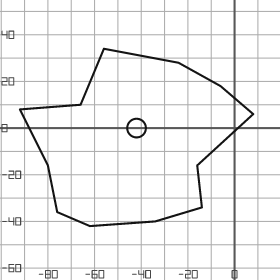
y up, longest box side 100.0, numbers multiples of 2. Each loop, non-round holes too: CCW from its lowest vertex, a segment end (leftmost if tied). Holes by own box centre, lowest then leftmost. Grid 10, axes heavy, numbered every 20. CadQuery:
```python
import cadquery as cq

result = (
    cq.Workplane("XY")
    .moveTo(-62.0, -42.0)
    .lineTo(-34.0, -40.0)
    .lineTo(-14.0, -34.0)
    .lineTo(-16.0, -16.0)
    .lineTo(8.0, 6.0)
    .lineTo(-6.0, 18.0)
    .lineTo(-24.0, 28.0)
    .lineTo(-56.0, 34.0)
    .lineTo(-66.0, 10.0)
    .lineTo(-92.0, 8.0)
    .lineTo(-80.0, -16.0)
    .lineTo(-76.0, -36.0)
    .close()
    .moveTo(-42.0, 0.0)
    .circle(4.0)
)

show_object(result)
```